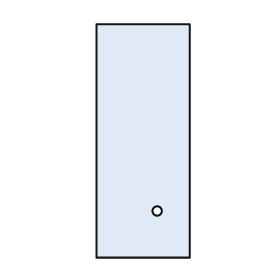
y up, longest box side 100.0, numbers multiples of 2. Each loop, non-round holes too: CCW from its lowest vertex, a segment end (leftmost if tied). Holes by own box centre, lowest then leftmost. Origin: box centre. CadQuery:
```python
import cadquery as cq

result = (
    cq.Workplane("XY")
    .moveTo(-20.0, -50.0)
    .lineTo(20.0, -50.0)
    .lineTo(20.0, 50.0)
    .lineTo(-20.0, 50.0)
    .close()
    .moveTo(6.0, -30.0)
    .circle(2.0)
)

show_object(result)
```